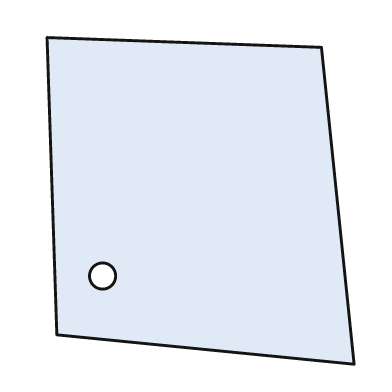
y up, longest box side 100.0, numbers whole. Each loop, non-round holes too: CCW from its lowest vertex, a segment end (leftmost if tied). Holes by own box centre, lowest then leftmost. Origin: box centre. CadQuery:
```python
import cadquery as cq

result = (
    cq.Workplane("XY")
    .moveTo(47.0, -50.0)
    .lineTo(37.0, 47.0)
    .lineTo(-47.0, 50.0)
    .lineTo(-44.0, -41.0)
    .close()
    .moveTo(-30.0, -23.0)
    .circle(4.0)
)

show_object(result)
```